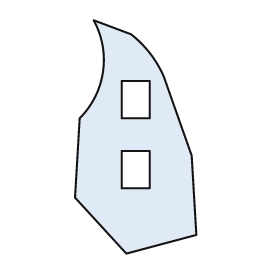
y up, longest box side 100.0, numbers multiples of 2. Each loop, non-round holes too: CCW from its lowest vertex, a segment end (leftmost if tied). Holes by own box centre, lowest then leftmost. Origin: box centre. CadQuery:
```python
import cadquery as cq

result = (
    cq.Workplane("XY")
    .moveTo(-4.0, -50.0)
    .lineTo(26.0, -42.0)
    .lineTo(24.0, -8.0)
    .lineTo(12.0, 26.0)
    .threePointArc((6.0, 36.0), (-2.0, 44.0))
    .lineTo(-18.0, 50.0)
    .threePointArc((-14.0, 28.0), (-24.0, 8.0))
    .lineTo(-26.0, -26.0)
    .close()
    .moveTo(-6.0, -22.0)
    .lineTo(6.0, -22.0)
    .lineTo(6.0, -6.0)
    .lineTo(-6.0, -6.0)
    .close()
    .moveTo(-6.0, 8.0)
    .lineTo(6.0, 8.0)
    .lineTo(6.0, 24.0)
    .lineTo(-6.0, 24.0)
    .close()
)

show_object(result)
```